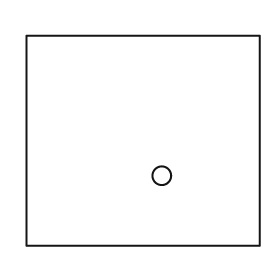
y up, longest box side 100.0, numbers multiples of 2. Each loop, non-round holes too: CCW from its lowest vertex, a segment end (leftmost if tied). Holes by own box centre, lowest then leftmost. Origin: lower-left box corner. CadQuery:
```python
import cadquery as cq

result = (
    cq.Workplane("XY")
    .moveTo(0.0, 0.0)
    .lineTo(100.0, 0.0)
    .lineTo(100.0, 90.0)
    .lineTo(0.0, 90.0)
    .close()
    .moveTo(58.0, 30.0)
    .circle(4.0)
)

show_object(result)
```